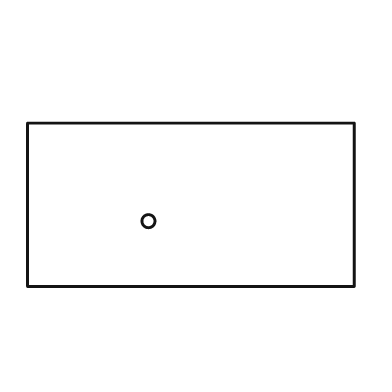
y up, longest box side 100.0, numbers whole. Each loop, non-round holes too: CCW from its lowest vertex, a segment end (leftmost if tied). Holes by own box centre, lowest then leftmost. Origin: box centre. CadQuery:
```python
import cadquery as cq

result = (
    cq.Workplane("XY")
    .moveTo(-50.0, -25.0)
    .lineTo(50.0, -25.0)
    .lineTo(50.0, 25.0)
    .lineTo(-50.0, 25.0)
    .close()
    .moveTo(-13.0, -5.0)
    .circle(2.0)
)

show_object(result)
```